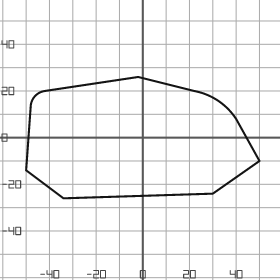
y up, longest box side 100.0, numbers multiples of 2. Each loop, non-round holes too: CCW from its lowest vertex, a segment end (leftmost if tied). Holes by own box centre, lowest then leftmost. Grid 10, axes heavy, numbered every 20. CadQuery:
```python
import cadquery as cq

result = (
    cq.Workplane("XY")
    .moveTo(-34.0, -26.0)
    .lineTo(30.0, -24.0)
    .lineTo(50.0, -10.0)
    .lineTo(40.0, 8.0)
    .threePointArc((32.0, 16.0), (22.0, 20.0))
    .lineTo(-2.0, 26.0)
    .lineTo(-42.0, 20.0)
    .threePointArc((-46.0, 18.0), (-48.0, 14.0))
    .lineTo(-50.0, -14.0)
    .close()
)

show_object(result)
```